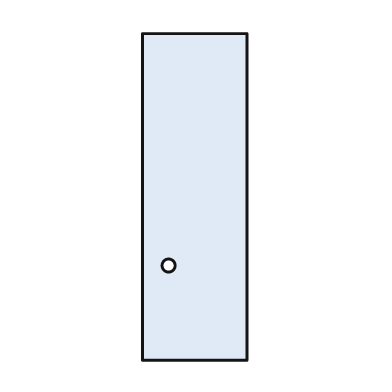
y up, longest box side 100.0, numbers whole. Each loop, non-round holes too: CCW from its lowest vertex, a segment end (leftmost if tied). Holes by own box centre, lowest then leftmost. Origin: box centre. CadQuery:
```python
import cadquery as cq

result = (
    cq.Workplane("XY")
    .moveTo(-16.0, -50.0)
    .lineTo(16.0, -50.0)
    .lineTo(16.0, 50.0)
    .lineTo(-16.0, 50.0)
    .close()
    .moveTo(-8.0, -21.0)
    .circle(2.0)
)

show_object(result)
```